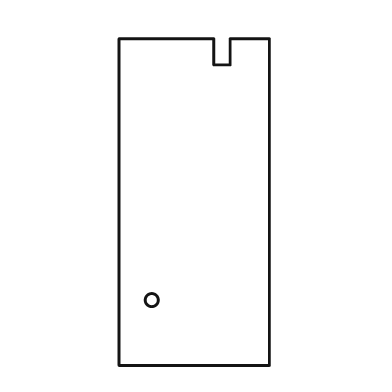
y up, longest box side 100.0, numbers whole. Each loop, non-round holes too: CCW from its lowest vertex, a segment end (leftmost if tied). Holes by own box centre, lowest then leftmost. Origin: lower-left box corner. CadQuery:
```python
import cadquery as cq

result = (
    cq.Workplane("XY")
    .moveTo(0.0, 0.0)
    .lineTo(46.0, 0.0)
    .lineTo(46.0, 100.0)
    .lineTo(34.0, 100.0)
    .lineTo(34.0, 92.0)
    .lineTo(29.0, 92.0)
    .lineTo(29.0, 100.0)
    .lineTo(0.0, 100.0)
    .close()
    .moveTo(10.0, 20.0)
    .circle(2.0)
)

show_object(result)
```